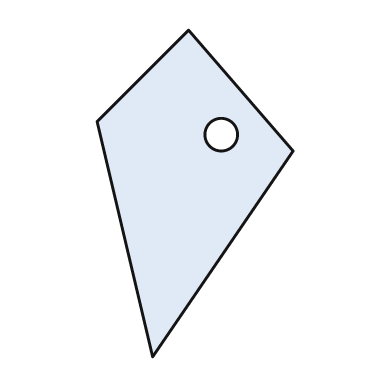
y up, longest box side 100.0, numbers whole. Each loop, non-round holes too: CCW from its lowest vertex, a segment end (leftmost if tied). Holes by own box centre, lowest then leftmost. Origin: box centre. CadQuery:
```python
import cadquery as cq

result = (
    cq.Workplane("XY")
    .moveTo(-13.0, -50.0)
    .lineTo(30.0, 13.0)
    .lineTo(-2.0, 50.0)
    .lineTo(-30.0, 22.0)
    .close()
    .moveTo(8.0, 18.0)
    .circle(5.0)
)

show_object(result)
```